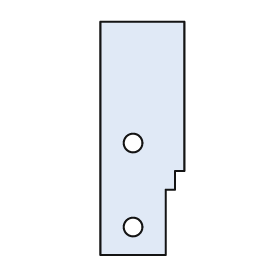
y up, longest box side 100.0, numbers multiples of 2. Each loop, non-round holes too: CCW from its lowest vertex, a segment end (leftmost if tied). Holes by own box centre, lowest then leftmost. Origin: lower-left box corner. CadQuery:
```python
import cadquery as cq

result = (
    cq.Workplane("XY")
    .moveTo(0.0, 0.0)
    .lineTo(28.0, 0.0)
    .lineTo(28.0, 28.0)
    .lineTo(32.0, 28.0)
    .lineTo(32.0, 36.0)
    .lineTo(36.0, 36.0)
    .lineTo(36.0, 100.0)
    .lineTo(0.0, 100.0)
    .close()
    .moveTo(14.0, 12.0)
    .circle(4.0)
    .moveTo(14.0, 48.0)
    .circle(4.0)
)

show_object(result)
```